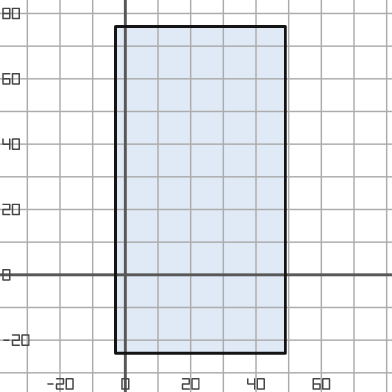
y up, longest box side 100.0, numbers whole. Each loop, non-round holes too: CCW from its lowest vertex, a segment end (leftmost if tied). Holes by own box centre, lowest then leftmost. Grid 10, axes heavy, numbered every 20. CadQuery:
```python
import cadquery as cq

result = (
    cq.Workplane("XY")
    .moveTo(-3.0, -24.0)
    .lineTo(49.0, -24.0)
    .lineTo(49.0, 76.0)
    .lineTo(-3.0, 76.0)
    .close()
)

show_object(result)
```